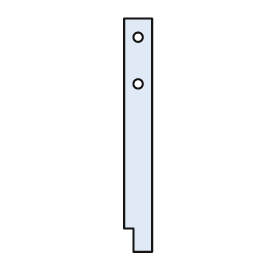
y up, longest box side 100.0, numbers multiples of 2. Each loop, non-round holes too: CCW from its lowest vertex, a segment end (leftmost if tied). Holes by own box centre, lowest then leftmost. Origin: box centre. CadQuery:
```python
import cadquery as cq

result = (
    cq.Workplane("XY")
    .moveTo(-2.0, -50.0)
    .lineTo(6.0, -50.0)
    .lineTo(6.0, 50.0)
    .lineTo(-6.0, 50.0)
    .lineTo(-6.0, -40.0)
    .lineTo(-2.0, -40.0)
    .close()
    .moveTo(0.0, 22.0)
    .circle(2.0)
    .moveTo(0.0, 42.0)
    .circle(2.0)
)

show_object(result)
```